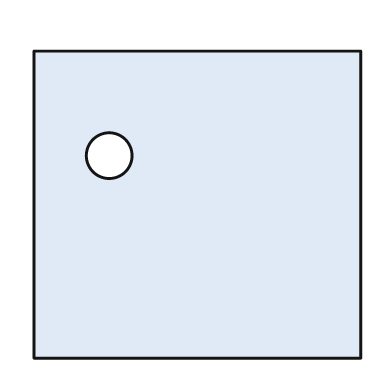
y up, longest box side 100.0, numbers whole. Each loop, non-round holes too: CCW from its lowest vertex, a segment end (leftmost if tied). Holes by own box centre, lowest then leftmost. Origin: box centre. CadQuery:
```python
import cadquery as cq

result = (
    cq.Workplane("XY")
    .moveTo(-50.0, -47.0)
    .lineTo(50.0, -47.0)
    .lineTo(50.0, 47.0)
    .lineTo(-50.0, 47.0)
    .close()
    .moveTo(-27.0, 15.0)
    .circle(7.0)
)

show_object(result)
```